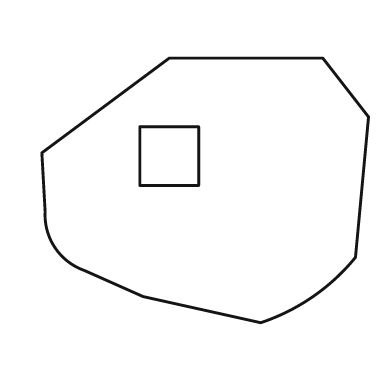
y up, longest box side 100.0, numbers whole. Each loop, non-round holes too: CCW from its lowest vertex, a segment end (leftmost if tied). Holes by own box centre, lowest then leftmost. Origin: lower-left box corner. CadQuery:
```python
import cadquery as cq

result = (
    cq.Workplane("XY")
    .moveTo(67.0, 0.0)
    .threePointArc((83.0, 8.0), (96.0, 20.0))
    .lineTo(100.0, 63.0)
    .lineTo(86.0, 81.0)
    .lineTo(39.0, 81.0)
    .lineTo(0.0, 52.0)
    .lineTo(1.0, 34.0)
    .threePointArc((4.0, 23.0), (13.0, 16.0))
    .lineTo(31.0, 8.0)
    .close()
    .moveTo(30.0, 42.0)
    .lineTo(48.0, 42.0)
    .lineTo(48.0, 60.0)
    .lineTo(30.0, 60.0)
    .close()
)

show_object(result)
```